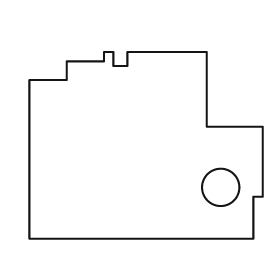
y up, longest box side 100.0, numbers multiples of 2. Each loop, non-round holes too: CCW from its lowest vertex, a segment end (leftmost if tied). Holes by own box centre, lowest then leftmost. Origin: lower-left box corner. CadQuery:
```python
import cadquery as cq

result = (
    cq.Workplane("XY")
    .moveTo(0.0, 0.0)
    .lineTo(96.0, 0.0)
    .lineTo(96.0, 18.0)
    .lineTo(100.0, 18.0)
    .lineTo(100.0, 48.0)
    .lineTo(76.0, 48.0)
    .lineTo(76.0, 80.0)
    .lineTo(42.0, 80.0)
    .lineTo(42.0, 74.0)
    .lineTo(36.0, 74.0)
    .lineTo(36.0, 80.0)
    .lineTo(32.0, 80.0)
    .lineTo(32.0, 76.0)
    .lineTo(16.0, 76.0)
    .lineTo(16.0, 68.0)
    .lineTo(0.0, 68.0)
    .close()
    .moveTo(82.0, 22.0)
    .circle(8.0)
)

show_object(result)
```